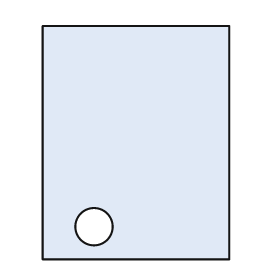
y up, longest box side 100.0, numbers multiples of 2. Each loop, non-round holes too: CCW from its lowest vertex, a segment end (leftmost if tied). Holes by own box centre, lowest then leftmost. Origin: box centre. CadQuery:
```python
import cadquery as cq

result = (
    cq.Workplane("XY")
    .moveTo(-40.0, -50.0)
    .lineTo(40.0, -50.0)
    .lineTo(40.0, 50.0)
    .lineTo(-40.0, 50.0)
    .close()
    .moveTo(-18.0, -36.0)
    .circle(8.0)
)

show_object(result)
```